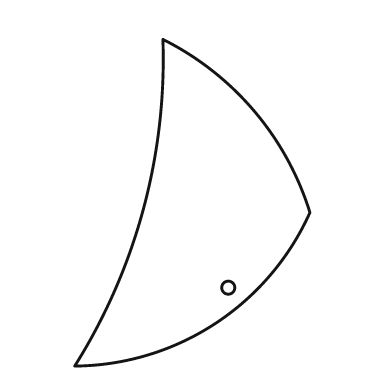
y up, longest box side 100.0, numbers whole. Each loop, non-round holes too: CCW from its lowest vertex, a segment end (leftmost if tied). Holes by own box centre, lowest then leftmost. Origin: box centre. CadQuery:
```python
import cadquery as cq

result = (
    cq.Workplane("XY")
    .moveTo(-36.0, -50.0)
    .threePointArc((7.0, -37.0), (36.0, -3.0))
    .threePointArc((19.0, 28.0), (-9.0, 50.0))
    .threePointArc((-15.0, -2.0), (-36.0, -50.0))
    .close()
    .moveTo(11.0, -26.0)
    .circle(2.0)
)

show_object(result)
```